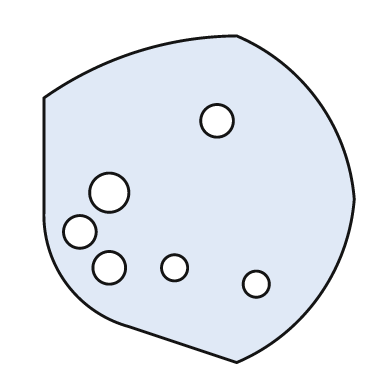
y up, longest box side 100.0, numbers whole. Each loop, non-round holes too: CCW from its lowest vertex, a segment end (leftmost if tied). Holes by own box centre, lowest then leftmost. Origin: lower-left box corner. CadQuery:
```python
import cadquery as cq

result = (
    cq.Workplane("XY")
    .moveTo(59.0, 0.0)
    .threePointArc((84.0, 20.0), (95.0, 50.0))
    .threePointArc((84.0, 80.0), (59.0, 100.0))
    .threePointArc((28.0, 95.0), (0.0, 81.0))
    .lineTo(0.0, 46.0)
    .threePointArc((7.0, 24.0), (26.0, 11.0))
    .close()
    .moveTo(65.0, 24.0)
    .circle(4.0)
    .moveTo(20.0, 29.0)
    .circle(5.0)
    .moveTo(40.0, 29.0)
    .circle(4.0)
    .moveTo(11.0, 40.0)
    .circle(5.0)
    .moveTo(20.0, 52.0)
    .circle(6.0)
    .moveTo(53.0, 74.0)
    .circle(5.0)
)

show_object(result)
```